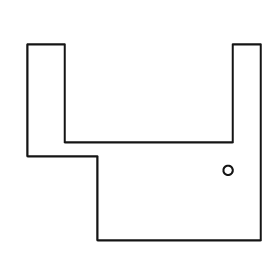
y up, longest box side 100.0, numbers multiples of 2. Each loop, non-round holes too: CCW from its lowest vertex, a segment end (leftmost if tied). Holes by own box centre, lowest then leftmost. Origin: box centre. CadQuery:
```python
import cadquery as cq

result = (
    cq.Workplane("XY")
    .moveTo(-20.0, -42.0)
    .lineTo(50.0, -42.0)
    .lineTo(50.0, 42.0)
    .lineTo(38.0, 42.0)
    .lineTo(38.0, 0.0)
    .lineTo(-34.0, 0.0)
    .lineTo(-34.0, 42.0)
    .lineTo(-50.0, 42.0)
    .lineTo(-50.0, -6.0)
    .lineTo(-20.0, -6.0)
    .close()
    .moveTo(36.0, -12.0)
    .circle(2.0)
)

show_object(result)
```